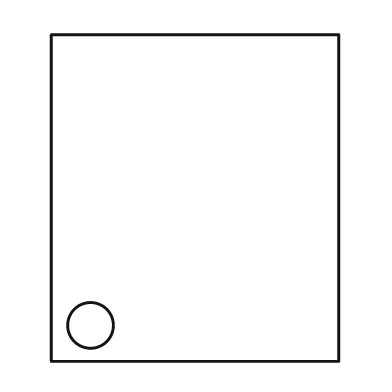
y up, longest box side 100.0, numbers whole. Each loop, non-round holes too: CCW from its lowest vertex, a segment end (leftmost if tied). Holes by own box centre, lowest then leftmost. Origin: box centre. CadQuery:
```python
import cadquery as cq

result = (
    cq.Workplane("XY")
    .moveTo(-44.0, -50.0)
    .lineTo(44.0, -50.0)
    .lineTo(44.0, 50.0)
    .lineTo(-44.0, 50.0)
    .close()
    .moveTo(-32.0, -39.0)
    .circle(7.0)
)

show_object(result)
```